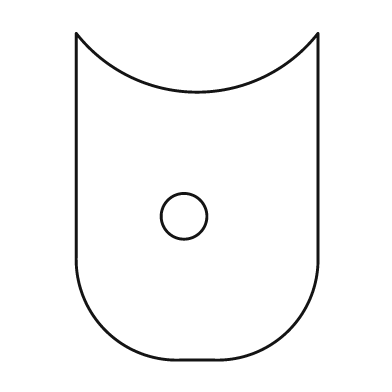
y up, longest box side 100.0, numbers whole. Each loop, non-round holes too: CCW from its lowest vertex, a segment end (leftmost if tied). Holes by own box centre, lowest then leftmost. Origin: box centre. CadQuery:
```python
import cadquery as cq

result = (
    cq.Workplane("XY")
    .moveTo(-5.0, -50.0)
    .lineTo(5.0, -50.0)
    .threePointArc((28.0, -41.0), (37.0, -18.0))
    .lineTo(37.0, 50.0)
    .threePointArc((0.0, 32.0), (-37.0, 50.0))
    .lineTo(-37.0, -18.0)
    .threePointArc((-28.0, -41.0), (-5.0, -50.0))
    .close()
    .moveTo(-4.0, -6.0)
    .circle(7.0)
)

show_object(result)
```